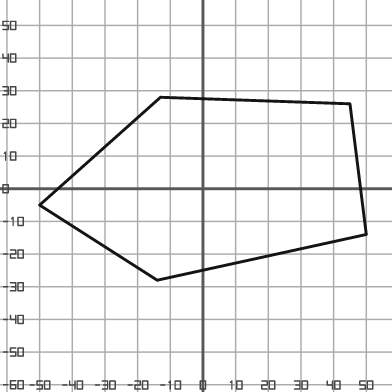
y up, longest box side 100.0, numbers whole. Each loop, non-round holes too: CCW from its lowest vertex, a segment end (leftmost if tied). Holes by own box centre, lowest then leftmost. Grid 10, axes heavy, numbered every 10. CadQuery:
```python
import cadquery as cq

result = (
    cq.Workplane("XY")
    .moveTo(-14.0, -28.0)
    .lineTo(50.0, -14.0)
    .lineTo(45.0, 26.0)
    .lineTo(-13.0, 28.0)
    .lineTo(-50.0, -5.0)
    .close()
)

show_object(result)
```